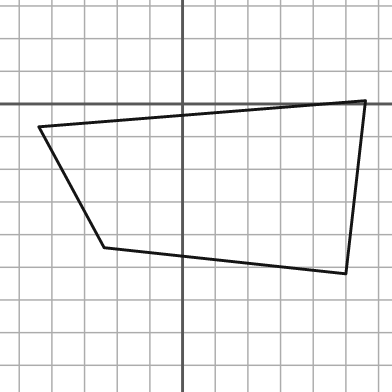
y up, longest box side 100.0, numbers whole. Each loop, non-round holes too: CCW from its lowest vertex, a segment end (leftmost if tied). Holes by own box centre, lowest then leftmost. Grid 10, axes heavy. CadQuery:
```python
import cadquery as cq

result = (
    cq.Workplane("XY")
    .moveTo(50.0, -52.0)
    .lineTo(56.0, 1.0)
    .lineTo(-44.0, -7.0)
    .lineTo(-24.0, -44.0)
    .close()
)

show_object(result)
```